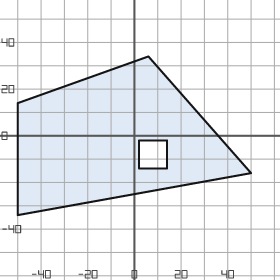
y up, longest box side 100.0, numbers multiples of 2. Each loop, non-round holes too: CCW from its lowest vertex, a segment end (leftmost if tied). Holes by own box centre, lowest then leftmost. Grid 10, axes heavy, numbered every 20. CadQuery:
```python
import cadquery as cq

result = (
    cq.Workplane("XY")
    .moveTo(-50.0, -34.0)
    .lineTo(50.0, -16.0)
    .lineTo(6.0, 34.0)
    .lineTo(-50.0, 14.0)
    .close()
    .moveTo(2.0, -14.0)
    .lineTo(14.0, -14.0)
    .lineTo(14.0, -2.0)
    .lineTo(2.0, -2.0)
    .close()
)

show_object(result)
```